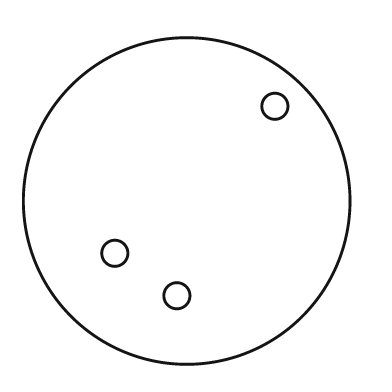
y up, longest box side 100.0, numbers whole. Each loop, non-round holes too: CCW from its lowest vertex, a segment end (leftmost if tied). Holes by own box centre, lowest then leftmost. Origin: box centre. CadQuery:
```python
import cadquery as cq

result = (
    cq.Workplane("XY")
    .moveTo(0.0, 0.0)
    .circle(50.0)
    .moveTo(-3.0, -29.0)
    .circle(4.0)
    .moveTo(-22.0, -16.0)
    .circle(4.0)
    .moveTo(27.0, 29.0)
    .circle(4.0)
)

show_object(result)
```